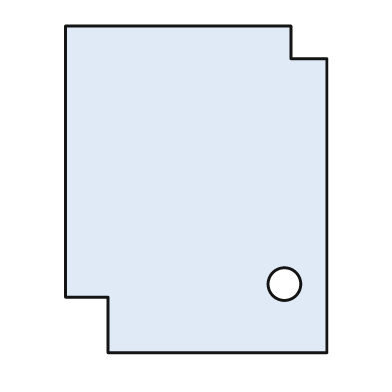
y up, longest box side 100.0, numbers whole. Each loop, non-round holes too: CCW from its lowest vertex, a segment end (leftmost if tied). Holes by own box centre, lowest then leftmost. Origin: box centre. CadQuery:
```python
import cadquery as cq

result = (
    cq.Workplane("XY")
    .moveTo(-27.0, -50.0)
    .lineTo(40.0, -50.0)
    .lineTo(40.0, 40.0)
    .lineTo(29.0, 40.0)
    .lineTo(29.0, 50.0)
    .lineTo(-40.0, 50.0)
    .lineTo(-40.0, -33.0)
    .lineTo(-27.0, -33.0)
    .close()
    .moveTo(27.0, -29.0)
    .circle(5.0)
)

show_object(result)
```